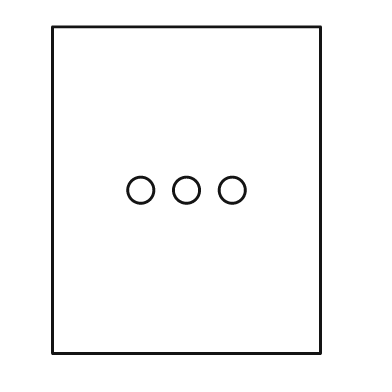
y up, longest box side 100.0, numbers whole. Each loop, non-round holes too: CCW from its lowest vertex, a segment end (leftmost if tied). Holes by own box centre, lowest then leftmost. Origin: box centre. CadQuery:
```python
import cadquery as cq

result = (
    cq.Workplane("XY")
    .moveTo(-41.0, -50.0)
    .lineTo(41.0, -50.0)
    .lineTo(41.0, 50.0)
    .lineTo(-41.0, 50.0)
    .close()
    .moveTo(-14.0, 0.0)
    .circle(4.0)
    .moveTo(0.0, 0.0)
    .circle(4.0)
    .moveTo(14.0, 0.0)
    .circle(4.0)
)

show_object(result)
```